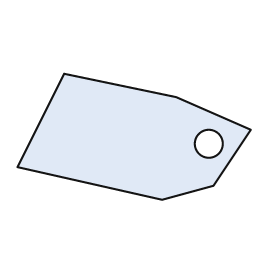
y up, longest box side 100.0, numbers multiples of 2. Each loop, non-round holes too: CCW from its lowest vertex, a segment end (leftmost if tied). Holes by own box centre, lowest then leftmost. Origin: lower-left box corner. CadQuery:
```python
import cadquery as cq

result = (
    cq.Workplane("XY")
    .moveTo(62.0, 0.0)
    .lineTo(84.0, 6.0)
    .lineTo(100.0, 30.0)
    .lineTo(68.0, 44.0)
    .lineTo(20.0, 54.0)
    .lineTo(0.0, 14.0)
    .close()
    .moveTo(82.0, 24.0)
    .circle(6.0)
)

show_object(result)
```